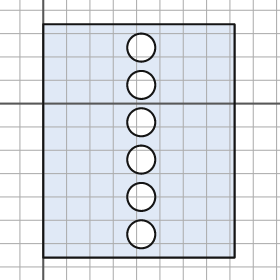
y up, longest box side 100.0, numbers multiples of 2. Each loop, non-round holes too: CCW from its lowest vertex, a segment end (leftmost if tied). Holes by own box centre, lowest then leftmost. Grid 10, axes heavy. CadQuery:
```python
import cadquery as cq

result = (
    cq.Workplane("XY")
    .moveTo(0.0, -66.0)
    .lineTo(82.0, -66.0)
    .lineTo(82.0, 34.0)
    .lineTo(0.0, 34.0)
    .close()
    .moveTo(42.0, -56.0)
    .circle(6.0)
    .moveTo(42.0, -40.0)
    .circle(6.0)
    .moveTo(42.0, -24.0)
    .circle(6.0)
    .moveTo(42.0, -8.0)
    .circle(6.0)
    .moveTo(42.0, 8.0)
    .circle(6.0)
    .moveTo(42.0, 24.0)
    .circle(6.0)
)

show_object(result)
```